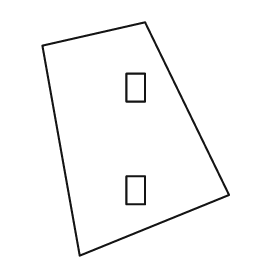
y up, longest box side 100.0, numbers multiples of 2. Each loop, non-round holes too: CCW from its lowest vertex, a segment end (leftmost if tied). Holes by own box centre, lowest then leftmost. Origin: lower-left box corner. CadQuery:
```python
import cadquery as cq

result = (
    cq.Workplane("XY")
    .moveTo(16.0, 0.0)
    .lineTo(80.0, 26.0)
    .lineTo(44.0, 100.0)
    .lineTo(0.0, 90.0)
    .close()
    .moveTo(36.0, 22.0)
    .lineTo(44.0, 22.0)
    .lineTo(44.0, 34.0)
    .lineTo(36.0, 34.0)
    .close()
    .moveTo(36.0, 66.0)
    .lineTo(44.0, 66.0)
    .lineTo(44.0, 78.0)
    .lineTo(36.0, 78.0)
    .close()
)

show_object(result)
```